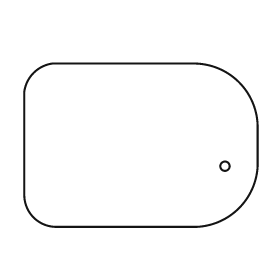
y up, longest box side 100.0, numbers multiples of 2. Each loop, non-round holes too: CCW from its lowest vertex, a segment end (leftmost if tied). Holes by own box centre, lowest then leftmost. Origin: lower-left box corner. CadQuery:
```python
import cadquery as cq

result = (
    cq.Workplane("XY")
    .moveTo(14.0, 0.0)
    .lineTo(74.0, 0.0)
    .threePointArc((92.0, 8.0), (100.0, 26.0))
    .lineTo(100.0, 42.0)
    .threePointArc((92.0, 62.0), (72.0, 70.0))
    .lineTo(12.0, 70.0)
    .threePointArc((4.0, 66.0), (0.0, 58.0))
    .lineTo(0.0, 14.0)
    .threePointArc((4.0, 4.0), (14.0, 0.0))
    .close()
    .moveTo(86.0, 26.0)
    .circle(2.0)
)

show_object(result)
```